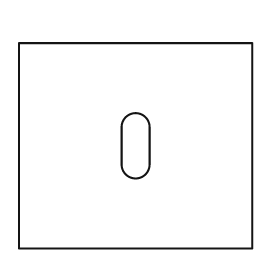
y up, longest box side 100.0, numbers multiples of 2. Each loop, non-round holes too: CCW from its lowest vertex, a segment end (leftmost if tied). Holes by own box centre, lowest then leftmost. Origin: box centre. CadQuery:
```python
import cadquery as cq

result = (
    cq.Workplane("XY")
    .moveTo(-50.0, -44.0)
    .lineTo(50.0, -44.0)
    .lineTo(50.0, 44.0)
    .lineTo(-50.0, 44.0)
    .close()
    .moveTo(-6.0, -8.0)
    .threePointArc((0.0, -14.0), (6.0, -8.0))
    .lineTo(6.0, 8.0)
    .threePointArc((0.0, 14.0), (-6.0, 8.0))
    .close()
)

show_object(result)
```